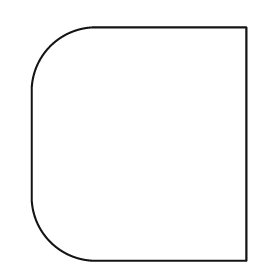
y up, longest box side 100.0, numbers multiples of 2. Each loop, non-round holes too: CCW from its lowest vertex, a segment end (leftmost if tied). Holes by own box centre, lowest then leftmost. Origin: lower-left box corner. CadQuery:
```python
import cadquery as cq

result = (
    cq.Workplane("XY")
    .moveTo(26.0, 0.0)
    .lineTo(92.0, 0.0)
    .lineTo(92.0, 100.0)
    .lineTo(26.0, 100.0)
    .threePointArc((8.0, 92.0), (0.0, 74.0))
    .lineTo(0.0, 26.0)
    .threePointArc((8.0, 8.0), (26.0, 0.0))
    .close()
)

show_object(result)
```